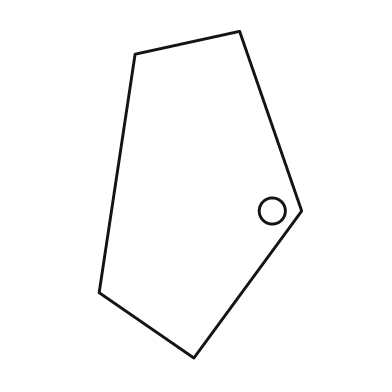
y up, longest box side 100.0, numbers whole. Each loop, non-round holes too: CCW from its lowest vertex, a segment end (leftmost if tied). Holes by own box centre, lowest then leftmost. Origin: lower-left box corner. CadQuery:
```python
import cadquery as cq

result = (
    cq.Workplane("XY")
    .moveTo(29.0, 0.0)
    .lineTo(62.0, 45.0)
    .lineTo(43.0, 100.0)
    .lineTo(11.0, 93.0)
    .lineTo(0.0, 20.0)
    .close()
    .moveTo(53.0, 45.0)
    .circle(4.0)
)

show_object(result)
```